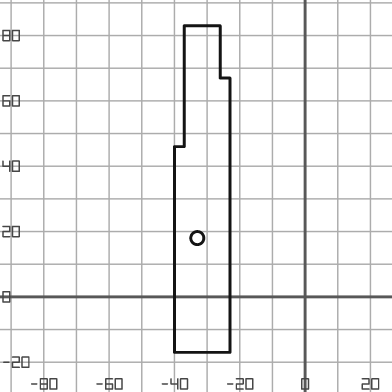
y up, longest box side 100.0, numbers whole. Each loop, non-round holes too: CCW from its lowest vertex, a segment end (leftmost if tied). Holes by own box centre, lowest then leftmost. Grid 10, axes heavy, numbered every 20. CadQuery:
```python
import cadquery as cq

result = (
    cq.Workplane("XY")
    .moveTo(-40.0, -17.0)
    .lineTo(-23.0, -17.0)
    .lineTo(-23.0, 67.0)
    .lineTo(-26.0, 67.0)
    .lineTo(-26.0, 83.0)
    .lineTo(-37.0, 83.0)
    .lineTo(-37.0, 46.0)
    .lineTo(-40.0, 46.0)
    .close()
    .moveTo(-33.0, 18.0)
    .circle(2.0)
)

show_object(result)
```